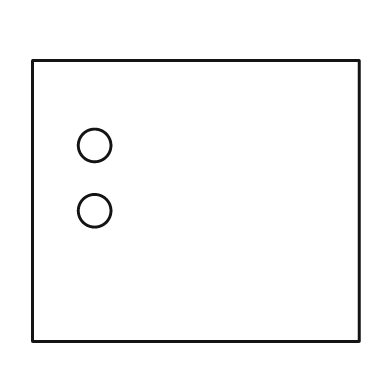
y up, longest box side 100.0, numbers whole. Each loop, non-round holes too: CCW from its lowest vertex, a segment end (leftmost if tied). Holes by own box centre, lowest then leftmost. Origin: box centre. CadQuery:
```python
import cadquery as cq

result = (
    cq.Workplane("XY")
    .moveTo(-50.0, -43.0)
    .lineTo(50.0, -43.0)
    .lineTo(50.0, 43.0)
    .lineTo(-50.0, 43.0)
    .close()
    .moveTo(-31.0, -3.0)
    .circle(5.0)
    .moveTo(-31.0, 17.0)
    .circle(5.0)
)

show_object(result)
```